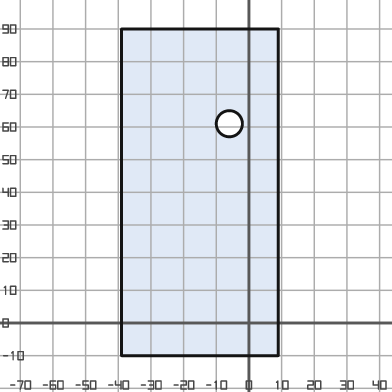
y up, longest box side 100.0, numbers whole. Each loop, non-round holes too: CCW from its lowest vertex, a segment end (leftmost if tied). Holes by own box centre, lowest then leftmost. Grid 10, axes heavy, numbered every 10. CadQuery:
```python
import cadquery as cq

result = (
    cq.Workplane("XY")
    .moveTo(-39.0, -10.0)
    .lineTo(9.0, -10.0)
    .lineTo(9.0, 90.0)
    .lineTo(-39.0, 90.0)
    .close()
    .moveTo(-6.0, 61.0)
    .circle(4.0)
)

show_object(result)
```